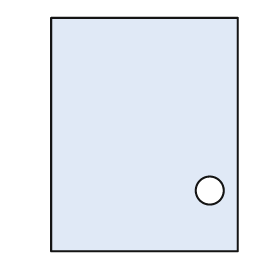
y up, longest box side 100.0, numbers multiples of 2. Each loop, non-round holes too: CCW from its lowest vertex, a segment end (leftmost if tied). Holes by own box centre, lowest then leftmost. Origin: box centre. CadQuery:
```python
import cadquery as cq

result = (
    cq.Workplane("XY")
    .moveTo(-40.0, -50.0)
    .lineTo(40.0, -50.0)
    .lineTo(40.0, 50.0)
    .lineTo(-40.0, 50.0)
    .close()
    .moveTo(28.0, -24.0)
    .circle(6.0)
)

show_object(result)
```